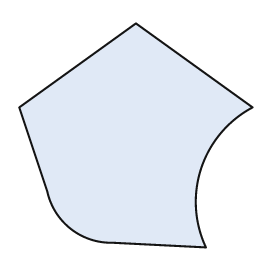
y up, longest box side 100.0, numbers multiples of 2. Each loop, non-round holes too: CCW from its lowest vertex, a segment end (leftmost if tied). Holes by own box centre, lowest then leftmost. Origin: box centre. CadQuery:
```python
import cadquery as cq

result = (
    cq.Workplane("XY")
    .moveTo(30.0, -48.0)
    .threePointArc((28.0, -14.0), (50.0, 12.0))
    .lineTo(0.0, 48.0)
    .lineTo(-50.0, 12.0)
    .lineTo(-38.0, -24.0)
    .threePointArc((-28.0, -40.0), (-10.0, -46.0))
    .close()
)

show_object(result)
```